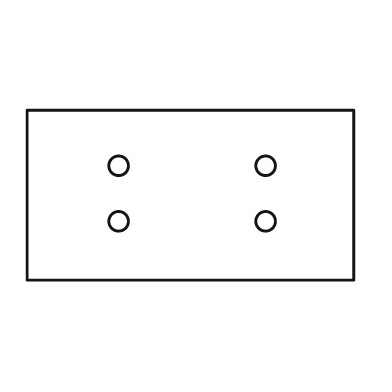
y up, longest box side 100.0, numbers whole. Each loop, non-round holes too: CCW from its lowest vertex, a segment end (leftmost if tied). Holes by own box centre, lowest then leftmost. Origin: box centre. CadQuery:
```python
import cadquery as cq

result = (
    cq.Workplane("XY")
    .moveTo(-50.0, -26.0)
    .lineTo(50.0, -26.0)
    .lineTo(50.0, 26.0)
    .lineTo(-50.0, 26.0)
    .close()
    .moveTo(-22.0, -8.0)
    .circle(3.0)
    .moveTo(23.0, -8.0)
    .circle(3.0)
    .moveTo(-22.0, 9.0)
    .circle(3.0)
    .moveTo(23.0, 9.0)
    .circle(3.0)
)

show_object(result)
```